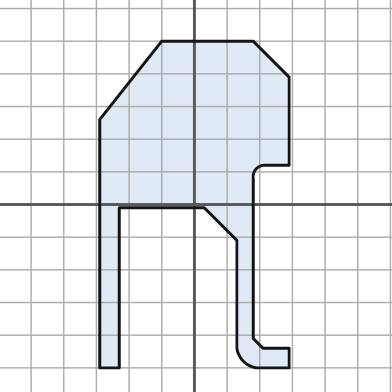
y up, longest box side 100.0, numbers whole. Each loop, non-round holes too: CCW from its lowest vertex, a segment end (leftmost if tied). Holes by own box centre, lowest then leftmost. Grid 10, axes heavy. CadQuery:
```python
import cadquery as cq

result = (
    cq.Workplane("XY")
    .moveTo(-29.0, -50.0)
    .lineTo(-23.0, -50.0)
    .lineTo(-23.0, -1.0)
    .lineTo(3.0, -1.0)
    .lineTo(13.0, -11.0)
    .lineTo(13.0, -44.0)
    .threePointArc((15.0, -48.0), (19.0, -50.0))
    .lineTo(29.0, -50.0)
    .lineTo(29.0, -44.0)
    .lineTo(21.0, -44.0)
    .lineTo(18.0, -41.0)
    .lineTo(18.0, 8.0)
    .threePointArc((19.0, 11.0), (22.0, 12.0))
    .lineTo(29.0, 12.0)
    .lineTo(29.0, 39.0)
    .lineTo(18.0, 50.0)
    .lineTo(-10.0, 50.0)
    .lineTo(-29.0, 26.0)
    .close()
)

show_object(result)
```